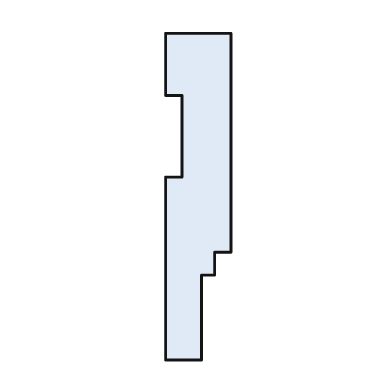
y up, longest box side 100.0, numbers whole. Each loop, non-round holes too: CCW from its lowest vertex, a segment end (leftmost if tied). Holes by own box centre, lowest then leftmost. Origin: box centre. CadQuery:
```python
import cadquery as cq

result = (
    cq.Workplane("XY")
    .moveTo(-10.0, -50.0)
    .lineTo(1.0, -50.0)
    .lineTo(1.0, -24.0)
    .lineTo(5.0, -24.0)
    .lineTo(5.0, -17.0)
    .lineTo(10.0, -17.0)
    .lineTo(10.0, 50.0)
    .lineTo(-10.0, 50.0)
    .lineTo(-10.0, 31.0)
    .lineTo(-5.0, 31.0)
    .lineTo(-5.0, 6.0)
    .lineTo(-10.0, 6.0)
    .close()
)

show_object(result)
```